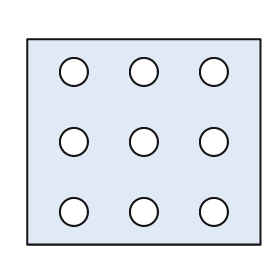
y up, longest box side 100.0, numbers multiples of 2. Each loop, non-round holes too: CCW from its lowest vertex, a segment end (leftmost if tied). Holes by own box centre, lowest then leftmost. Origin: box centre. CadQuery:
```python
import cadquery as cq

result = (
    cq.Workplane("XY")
    .moveTo(-50.0, -44.0)
    .lineTo(50.0, -44.0)
    .lineTo(50.0, 44.0)
    .lineTo(-50.0, 44.0)
    .close()
    .moveTo(-30.0, -30.0)
    .circle(6.0)
    .moveTo(0.0, -30.0)
    .circle(6.0)
    .moveTo(30.0, -30.0)
    .circle(6.0)
    .moveTo(-30.0, 0.0)
    .circle(6.0)
    .moveTo(0.0, 0.0)
    .circle(6.0)
    .moveTo(30.0, 0.0)
    .circle(6.0)
    .moveTo(-30.0, 30.0)
    .circle(6.0)
    .moveTo(0.0, 30.0)
    .circle(6.0)
    .moveTo(30.0, 30.0)
    .circle(6.0)
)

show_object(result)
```